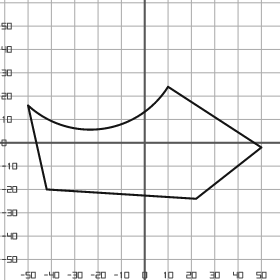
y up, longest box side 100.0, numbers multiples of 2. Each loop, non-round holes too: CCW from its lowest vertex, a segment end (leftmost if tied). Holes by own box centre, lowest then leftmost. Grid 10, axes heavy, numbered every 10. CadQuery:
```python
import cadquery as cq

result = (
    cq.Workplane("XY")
    .moveTo(22.0, -24.0)
    .lineTo(50.0, -2.0)
    .lineTo(10.0, 24.0)
    .threePointArc((-18.0, 6.0), (-50.0, 16.0))
    .lineTo(-42.0, -20.0)
    .close()
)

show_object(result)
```